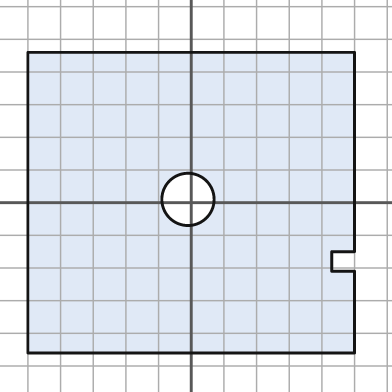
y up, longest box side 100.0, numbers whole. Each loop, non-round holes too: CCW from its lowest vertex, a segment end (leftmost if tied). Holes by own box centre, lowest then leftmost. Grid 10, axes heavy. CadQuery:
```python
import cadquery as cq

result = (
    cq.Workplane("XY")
    .moveTo(-50.0, -46.0)
    .lineTo(50.0, -46.0)
    .lineTo(50.0, -21.0)
    .lineTo(43.0, -21.0)
    .lineTo(43.0, -15.0)
    .lineTo(50.0, -15.0)
    .lineTo(50.0, 46.0)
    .lineTo(-50.0, 46.0)
    .close()
    .moveTo(-1.0, 1.0)
    .circle(8.0)
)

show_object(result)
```